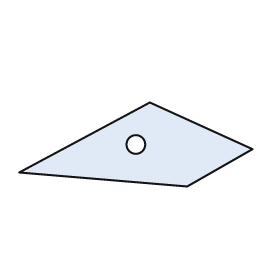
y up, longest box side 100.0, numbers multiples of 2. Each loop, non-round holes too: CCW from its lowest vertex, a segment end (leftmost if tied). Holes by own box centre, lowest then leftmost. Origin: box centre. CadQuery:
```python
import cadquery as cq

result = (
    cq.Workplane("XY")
    .moveTo(22.0, -18.0)
    .lineTo(50.0, -2.0)
    .lineTo(6.0, 18.0)
    .lineTo(-50.0, -12.0)
    .close()
    .moveTo(0.0, 0.0)
    .circle(4.0)
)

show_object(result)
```